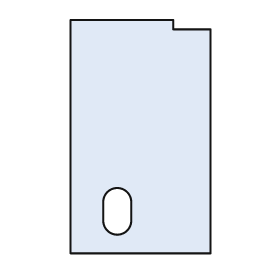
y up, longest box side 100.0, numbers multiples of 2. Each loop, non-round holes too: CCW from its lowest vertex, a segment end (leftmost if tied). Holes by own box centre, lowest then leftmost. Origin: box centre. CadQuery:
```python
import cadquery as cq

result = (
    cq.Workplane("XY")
    .moveTo(-30.0, -50.0)
    .lineTo(30.0, -50.0)
    .lineTo(30.0, 46.0)
    .lineTo(14.0, 46.0)
    .lineTo(14.0, 50.0)
    .lineTo(-30.0, 50.0)
    .close()
    .moveTo(-16.0, -36.0)
    .threePointArc((-10.0, -42.0), (-4.0, -36.0))
    .lineTo(-4.0, -28.0)
    .threePointArc((-10.0, -22.0), (-16.0, -28.0))
    .close()
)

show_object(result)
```